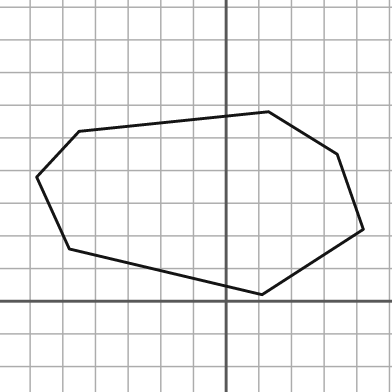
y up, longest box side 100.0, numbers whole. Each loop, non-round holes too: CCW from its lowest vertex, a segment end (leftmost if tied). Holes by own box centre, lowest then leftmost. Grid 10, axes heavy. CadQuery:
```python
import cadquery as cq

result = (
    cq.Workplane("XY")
    .moveTo(11.0, 2.0)
    .lineTo(42.0, 22.0)
    .lineTo(34.0, 45.0)
    .lineTo(13.0, 58.0)
    .lineTo(-45.0, 52.0)
    .lineTo(-58.0, 38.0)
    .lineTo(-48.0, 16.0)
    .close()
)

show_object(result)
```